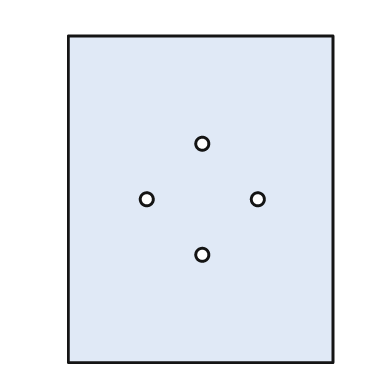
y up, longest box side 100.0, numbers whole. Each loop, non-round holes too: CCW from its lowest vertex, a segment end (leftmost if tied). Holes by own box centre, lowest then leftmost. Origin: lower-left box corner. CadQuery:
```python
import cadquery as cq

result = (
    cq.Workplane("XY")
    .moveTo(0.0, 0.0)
    .lineTo(81.0, 0.0)
    .lineTo(81.0, 100.0)
    .lineTo(0.0, 100.0)
    .close()
    .moveTo(41.0, 33.0)
    .circle(2.0)
    .moveTo(24.0, 50.0)
    .circle(2.0)
    .moveTo(58.0, 50.0)
    .circle(2.0)
    .moveTo(41.0, 67.0)
    .circle(2.0)
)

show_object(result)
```